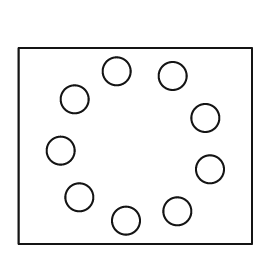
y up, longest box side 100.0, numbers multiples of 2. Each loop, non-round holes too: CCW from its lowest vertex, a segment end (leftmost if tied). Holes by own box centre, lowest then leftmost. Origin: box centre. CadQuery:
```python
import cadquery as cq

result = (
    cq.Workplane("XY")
    .moveTo(-50.0, -42.0)
    .lineTo(50.0, -42.0)
    .lineTo(50.0, 42.0)
    .lineTo(-50.0, 42.0)
    .close()
    .moveTo(-4.0, -32.0)
    .circle(6.0)
    .moveTo(18.0, -28.0)
    .circle(6.0)
    .moveTo(-24.0, -22.0)
    .circle(6.0)
    .moveTo(32.0, -10.0)
    .circle(6.0)
    .moveTo(-32.0, -2.0)
    .circle(6.0)
    .moveTo(30.0, 12.0)
    .circle(6.0)
    .moveTo(-26.0, 20.0)
    .circle(6.0)
    .moveTo(16.0, 30.0)
    .circle(6.0)
    .moveTo(-8.0, 32.0)
    .circle(6.0)
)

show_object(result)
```